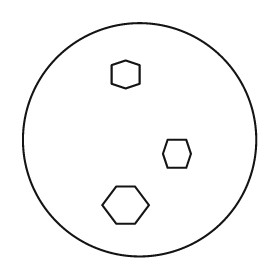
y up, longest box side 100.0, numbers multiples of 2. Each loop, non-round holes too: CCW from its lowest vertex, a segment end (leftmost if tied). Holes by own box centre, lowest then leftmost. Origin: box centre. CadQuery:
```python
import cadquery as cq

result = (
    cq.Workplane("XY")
    .moveTo(0.0, 0.0)
    .circle(50.0)
    .moveTo(-10.0, -36.0)
    .lineTo(-2.0, -36.0)
    .lineTo(4.0, -28.0)
    .lineTo(-2.0, -20.0)
    .lineTo(-10.0, -20.0)
    .lineTo(-16.0, -28.0)
    .close()
    .moveTo(12.0, -12.0)
    .lineTo(20.0, -12.0)
    .lineTo(22.0, -6.0)
    .lineTo(20.0, 0.0)
    .lineTo(12.0, 0.0)
    .lineTo(10.0, -6.0)
    .close()
    .moveTo(-6.0, 22.0)
    .lineTo(0.0, 24.0)
    .lineTo(0.0, 32.0)
    .lineTo(-6.0, 34.0)
    .lineTo(-12.0, 32.0)
    .lineTo(-12.0, 24.0)
    .close()
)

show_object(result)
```